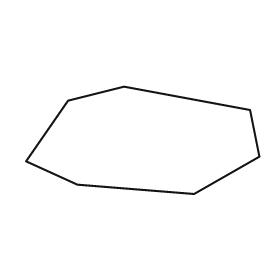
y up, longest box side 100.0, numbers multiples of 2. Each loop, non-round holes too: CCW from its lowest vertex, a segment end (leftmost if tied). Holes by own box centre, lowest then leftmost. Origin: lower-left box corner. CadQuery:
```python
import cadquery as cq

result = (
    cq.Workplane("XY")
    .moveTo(72.0, 0.0)
    .lineTo(100.0, 16.0)
    .lineTo(96.0, 36.0)
    .lineTo(42.0, 46.0)
    .lineTo(18.0, 40.0)
    .lineTo(0.0, 14.0)
    .lineTo(22.0, 4.0)
    .close()
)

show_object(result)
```